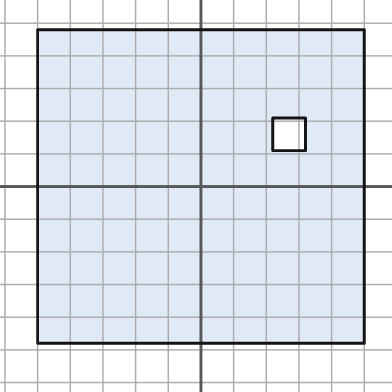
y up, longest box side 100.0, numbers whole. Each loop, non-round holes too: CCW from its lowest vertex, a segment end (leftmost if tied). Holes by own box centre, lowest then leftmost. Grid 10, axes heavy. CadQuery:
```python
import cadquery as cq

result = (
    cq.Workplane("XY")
    .moveTo(-50.0, -48.0)
    .lineTo(50.0, -48.0)
    .lineTo(50.0, 48.0)
    .lineTo(-50.0, 48.0)
    .close()
    .moveTo(22.0, 11.0)
    .lineTo(32.0, 11.0)
    .lineTo(32.0, 21.0)
    .lineTo(22.0, 21.0)
    .close()
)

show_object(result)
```